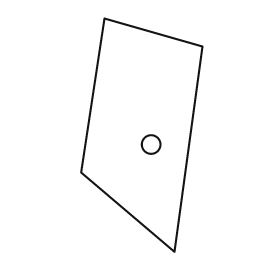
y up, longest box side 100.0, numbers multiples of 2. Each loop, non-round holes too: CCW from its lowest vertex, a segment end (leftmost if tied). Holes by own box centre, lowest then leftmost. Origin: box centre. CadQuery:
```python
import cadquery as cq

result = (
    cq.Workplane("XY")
    .moveTo(14.0, -50.0)
    .lineTo(26.0, 38.0)
    .lineTo(-16.0, 50.0)
    .lineTo(-26.0, -16.0)
    .close()
    .moveTo(4.0, -4.0)
    .circle(4.0)
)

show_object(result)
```